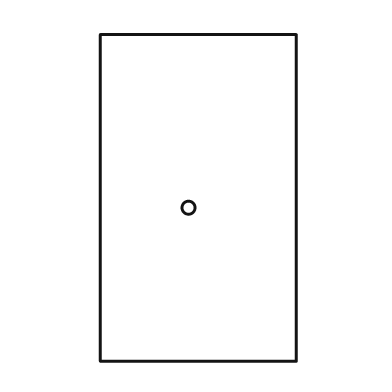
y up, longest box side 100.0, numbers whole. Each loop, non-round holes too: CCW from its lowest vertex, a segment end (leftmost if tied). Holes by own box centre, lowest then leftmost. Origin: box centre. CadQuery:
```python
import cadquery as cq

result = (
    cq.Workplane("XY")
    .moveTo(-30.0, -50.0)
    .lineTo(30.0, -50.0)
    .lineTo(30.0, 50.0)
    .lineTo(-30.0, 50.0)
    .close()
    .moveTo(-3.0, -3.0)
    .circle(2.0)
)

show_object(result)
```